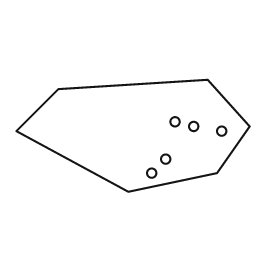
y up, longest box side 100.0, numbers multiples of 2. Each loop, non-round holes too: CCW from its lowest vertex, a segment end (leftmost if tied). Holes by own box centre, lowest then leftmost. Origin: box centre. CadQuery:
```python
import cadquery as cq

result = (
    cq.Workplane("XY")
    .moveTo(-2.0, -24.0)
    .lineTo(36.0, -16.0)
    .lineTo(50.0, 4.0)
    .lineTo(32.0, 24.0)
    .lineTo(-32.0, 20.0)
    .lineTo(-50.0, 2.0)
    .close()
    .moveTo(8.0, -16.0)
    .circle(2.0)
    .moveTo(14.0, -10.0)
    .circle(2.0)
    .moveTo(38.0, 2.0)
    .circle(2.0)
    .moveTo(26.0, 4.0)
    .circle(2.0)
    .moveTo(18.0, 6.0)
    .circle(2.0)
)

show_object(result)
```